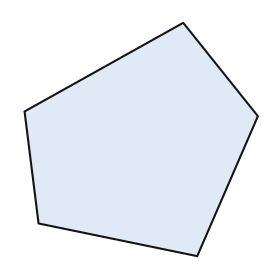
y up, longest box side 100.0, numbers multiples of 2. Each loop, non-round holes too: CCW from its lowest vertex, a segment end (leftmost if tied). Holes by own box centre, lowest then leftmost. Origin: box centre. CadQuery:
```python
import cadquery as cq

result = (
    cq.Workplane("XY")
    .moveTo(24.0, -50.0)
    .lineTo(50.0, 10.0)
    .lineTo(18.0, 50.0)
    .lineTo(-50.0, 12.0)
    .lineTo(-44.0, -36.0)
    .close()
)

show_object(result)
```